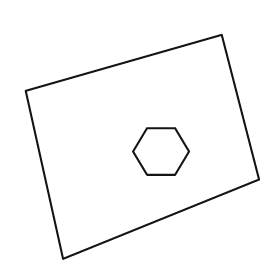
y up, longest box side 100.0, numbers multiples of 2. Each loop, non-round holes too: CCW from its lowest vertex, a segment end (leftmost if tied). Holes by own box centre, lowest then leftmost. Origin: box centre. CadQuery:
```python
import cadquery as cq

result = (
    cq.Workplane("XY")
    .moveTo(-34.0, -48.0)
    .lineTo(50.0, -14.0)
    .lineTo(34.0, 48.0)
    .lineTo(-50.0, 24.0)
    .close()
    .moveTo(2.0, -12.0)
    .lineTo(14.0, -12.0)
    .lineTo(20.0, -2.0)
    .lineTo(14.0, 8.0)
    .lineTo(2.0, 8.0)
    .lineTo(-4.0, -2.0)
    .close()
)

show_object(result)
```